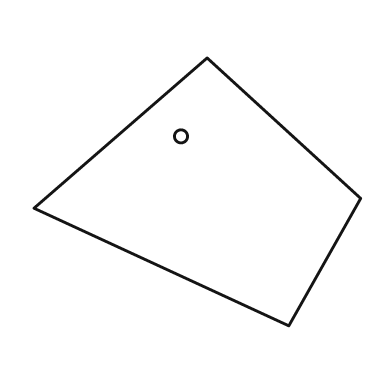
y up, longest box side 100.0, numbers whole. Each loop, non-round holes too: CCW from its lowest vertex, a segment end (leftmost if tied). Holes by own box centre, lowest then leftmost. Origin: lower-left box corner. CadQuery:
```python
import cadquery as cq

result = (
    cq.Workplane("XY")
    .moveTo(78.0, 0.0)
    .lineTo(100.0, 39.0)
    .lineTo(53.0, 82.0)
    .lineTo(0.0, 36.0)
    .close()
    .moveTo(45.0, 58.0)
    .circle(2.0)
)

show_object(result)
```